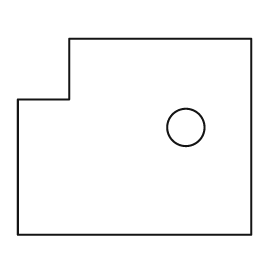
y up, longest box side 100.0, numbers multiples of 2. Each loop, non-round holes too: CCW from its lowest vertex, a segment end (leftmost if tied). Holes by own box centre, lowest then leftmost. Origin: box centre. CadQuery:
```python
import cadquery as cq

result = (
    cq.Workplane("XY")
    .moveTo(-50.0, -42.0)
    .lineTo(50.0, -42.0)
    .lineTo(50.0, 42.0)
    .lineTo(-28.0, 42.0)
    .lineTo(-28.0, 16.0)
    .lineTo(-50.0, 16.0)
    .close()
    .moveTo(22.0, 4.0)
    .circle(8.0)
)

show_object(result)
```